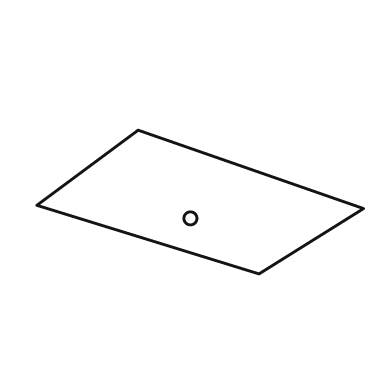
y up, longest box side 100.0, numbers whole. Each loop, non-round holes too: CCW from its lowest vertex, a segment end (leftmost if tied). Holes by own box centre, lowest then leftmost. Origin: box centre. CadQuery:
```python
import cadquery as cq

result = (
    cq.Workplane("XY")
    .moveTo(18.0, -22.0)
    .lineTo(50.0, -2.0)
    .lineTo(-19.0, 22.0)
    .lineTo(-50.0, -1.0)
    .close()
    .moveTo(-3.0, -5.0)
    .circle(2.0)
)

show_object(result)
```